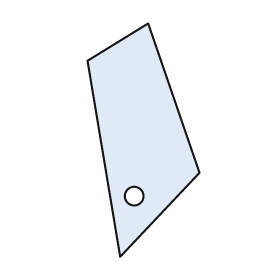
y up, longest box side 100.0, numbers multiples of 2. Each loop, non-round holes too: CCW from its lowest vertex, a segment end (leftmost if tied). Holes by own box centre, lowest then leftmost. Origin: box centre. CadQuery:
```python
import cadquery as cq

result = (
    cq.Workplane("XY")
    .moveTo(-10.0, -50.0)
    .lineTo(24.0, -14.0)
    .lineTo(2.0, 50.0)
    .lineTo(-24.0, 34.0)
    .close()
    .moveTo(-4.0, -24.0)
    .circle(4.0)
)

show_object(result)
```